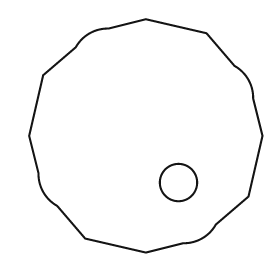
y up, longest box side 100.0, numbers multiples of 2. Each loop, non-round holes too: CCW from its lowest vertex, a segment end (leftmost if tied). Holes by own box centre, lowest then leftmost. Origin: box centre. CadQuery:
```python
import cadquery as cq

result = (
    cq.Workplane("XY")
    .moveTo(0.0, -50.0)
    .lineTo(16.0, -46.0)
    .threePointArc((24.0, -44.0), (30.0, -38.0))
    .lineTo(44.0, -26.0)
    .lineTo(50.0, 0.0)
    .lineTo(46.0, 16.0)
    .threePointArc((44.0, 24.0), (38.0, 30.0))
    .lineTo(26.0, 44.0)
    .lineTo(0.0, 50.0)
    .lineTo(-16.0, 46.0)
    .threePointArc((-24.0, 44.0), (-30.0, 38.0))
    .lineTo(-44.0, 26.0)
    .lineTo(-50.0, 0.0)
    .lineTo(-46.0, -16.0)
    .threePointArc((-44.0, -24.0), (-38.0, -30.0))
    .lineTo(-26.0, -44.0)
    .close()
    .moveTo(14.0, -20.0)
    .circle(8.0)
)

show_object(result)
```